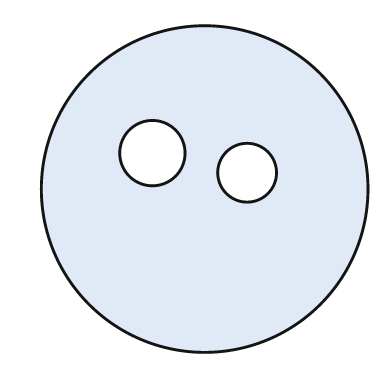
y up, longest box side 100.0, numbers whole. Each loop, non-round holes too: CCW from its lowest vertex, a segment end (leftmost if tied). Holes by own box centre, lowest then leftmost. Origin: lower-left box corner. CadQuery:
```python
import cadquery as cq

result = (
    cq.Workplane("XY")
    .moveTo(50.0, 50.0)
    .circle(50.0)
    .moveTo(63.0, 55.0)
    .circle(9.0)
    .moveTo(34.0, 61.0)
    .circle(10.0)
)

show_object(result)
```